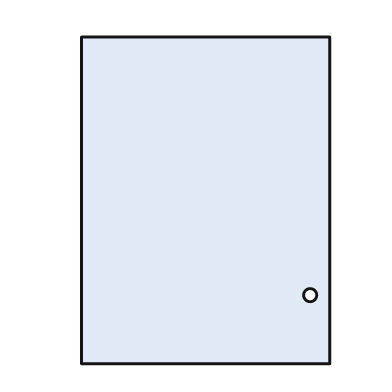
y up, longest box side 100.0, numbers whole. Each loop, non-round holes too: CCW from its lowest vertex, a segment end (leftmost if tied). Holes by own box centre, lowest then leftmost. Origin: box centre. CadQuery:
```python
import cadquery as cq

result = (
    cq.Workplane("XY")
    .moveTo(-38.0, -50.0)
    .lineTo(38.0, -50.0)
    .lineTo(38.0, 50.0)
    .lineTo(-38.0, 50.0)
    .close()
    .moveTo(32.0, -29.0)
    .circle(2.0)
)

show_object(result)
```